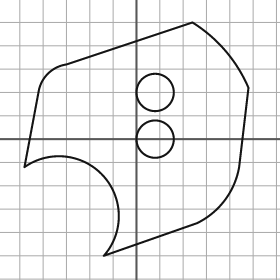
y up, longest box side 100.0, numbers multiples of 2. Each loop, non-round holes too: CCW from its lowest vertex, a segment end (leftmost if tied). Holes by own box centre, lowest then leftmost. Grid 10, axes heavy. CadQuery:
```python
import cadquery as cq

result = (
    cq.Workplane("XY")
    .moveTo(-14.0, -50.0)
    .lineTo(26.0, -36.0)
    .threePointArc((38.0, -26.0), (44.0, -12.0))
    .lineTo(48.0, 22.0)
    .threePointArc((38.0, 38.0), (24.0, 50.0))
    .lineTo(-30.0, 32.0)
    .threePointArc((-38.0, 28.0), (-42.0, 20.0))
    .lineTo(-48.0, -12.0)
    .threePointArc((-14.0, -16.0), (-14.0, -50.0))
    .close()
    .moveTo(8.0, 0.0)
    .circle(8.0)
    .moveTo(8.0, 20.0)
    .circle(8.0)
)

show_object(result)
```